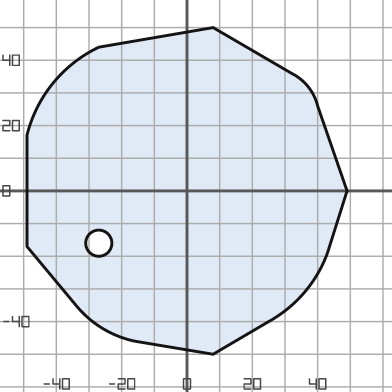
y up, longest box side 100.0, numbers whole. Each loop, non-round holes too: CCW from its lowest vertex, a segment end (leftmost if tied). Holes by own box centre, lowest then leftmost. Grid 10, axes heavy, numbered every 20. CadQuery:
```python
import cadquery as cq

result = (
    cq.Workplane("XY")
    .moveTo(8.0, -50.0)
    .lineTo(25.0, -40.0)
    .threePointArc((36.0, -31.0), (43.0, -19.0))
    .lineTo(49.0, 0.0)
    .lineTo(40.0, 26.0)
    .threePointArc((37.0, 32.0), (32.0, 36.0))
    .lineTo(8.0, 50.0)
    .lineTo(-27.0, 44.0)
    .threePointArc((-41.0, 33.0), (-49.0, 17.0))
    .lineTo(-49.0, -17.0)
    .lineTo(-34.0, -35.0)
    .threePointArc((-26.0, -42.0), (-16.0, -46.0))
    .close()
    .moveTo(-27.0, -16.0)
    .circle(4.0)
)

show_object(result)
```